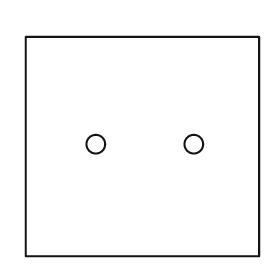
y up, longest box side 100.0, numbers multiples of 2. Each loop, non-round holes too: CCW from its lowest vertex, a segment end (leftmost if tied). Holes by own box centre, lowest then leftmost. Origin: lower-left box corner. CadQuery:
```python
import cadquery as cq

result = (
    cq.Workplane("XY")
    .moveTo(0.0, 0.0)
    .lineTo(100.0, 0.0)
    .lineTo(100.0, 94.0)
    .lineTo(0.0, 94.0)
    .close()
    .moveTo(30.0, 48.0)
    .circle(4.0)
    .moveTo(72.0, 48.0)
    .circle(4.0)
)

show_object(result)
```